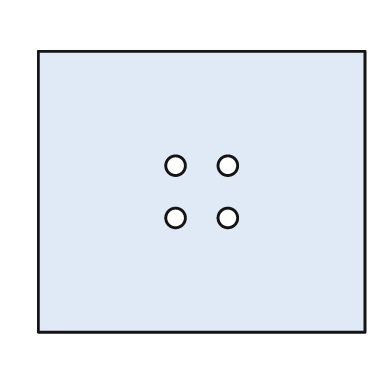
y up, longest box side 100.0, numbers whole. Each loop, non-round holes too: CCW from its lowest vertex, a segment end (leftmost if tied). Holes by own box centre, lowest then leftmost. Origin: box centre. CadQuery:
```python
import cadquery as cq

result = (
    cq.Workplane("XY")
    .moveTo(-50.0, -43.0)
    .lineTo(50.0, -43.0)
    .lineTo(50.0, 43.0)
    .lineTo(-50.0, 43.0)
    .close()
    .moveTo(-8.0, -8.0)
    .circle(3.0)
    .moveTo(8.0, -8.0)
    .circle(3.0)
    .moveTo(-8.0, 8.0)
    .circle(3.0)
    .moveTo(8.0, 8.0)
    .circle(3.0)
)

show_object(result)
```